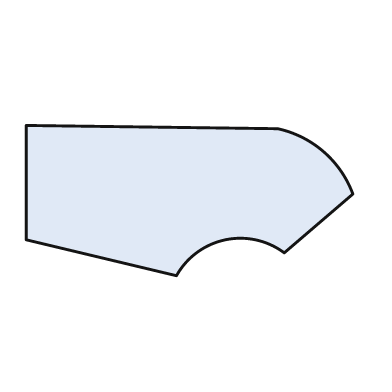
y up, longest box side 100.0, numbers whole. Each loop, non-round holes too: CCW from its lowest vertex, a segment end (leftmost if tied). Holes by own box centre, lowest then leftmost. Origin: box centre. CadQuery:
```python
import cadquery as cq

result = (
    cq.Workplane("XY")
    .moveTo(-4.0, -23.0)
    .threePointArc((11.0, -12.0), (29.0, -16.0))
    .lineTo(50.0, 2.0)
    .threePointArc((41.0, 15.0), (27.0, 22.0))
    .lineTo(-50.0, 23.0)
    .lineTo(-50.0, -12.0)
    .close()
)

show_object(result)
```